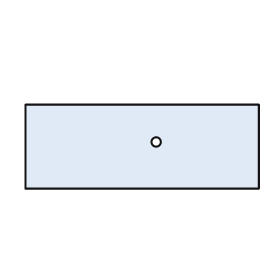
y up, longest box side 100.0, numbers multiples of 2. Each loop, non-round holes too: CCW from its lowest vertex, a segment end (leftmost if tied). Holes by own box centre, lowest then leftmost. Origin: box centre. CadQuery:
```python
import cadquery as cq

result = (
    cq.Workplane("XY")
    .moveTo(-50.0, -18.0)
    .lineTo(50.0, -18.0)
    .lineTo(50.0, 18.0)
    .lineTo(-50.0, 18.0)
    .close()
    .moveTo(6.0, 2.0)
    .circle(2.0)
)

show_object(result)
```